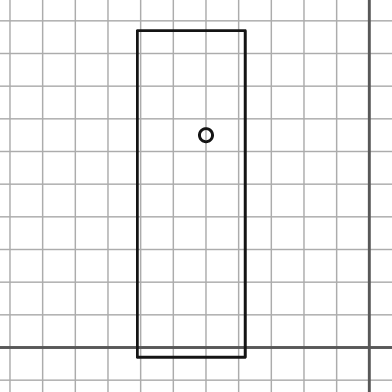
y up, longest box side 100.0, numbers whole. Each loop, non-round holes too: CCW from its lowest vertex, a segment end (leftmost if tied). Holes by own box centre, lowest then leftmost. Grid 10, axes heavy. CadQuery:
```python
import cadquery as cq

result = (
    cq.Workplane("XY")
    .moveTo(-71.0, -3.0)
    .lineTo(-38.0, -3.0)
    .lineTo(-38.0, 97.0)
    .lineTo(-71.0, 97.0)
    .close()
    .moveTo(-50.0, 65.0)
    .circle(2.0)
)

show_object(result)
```